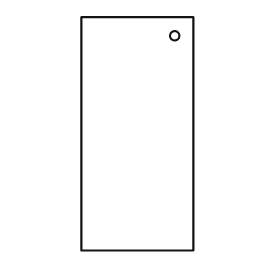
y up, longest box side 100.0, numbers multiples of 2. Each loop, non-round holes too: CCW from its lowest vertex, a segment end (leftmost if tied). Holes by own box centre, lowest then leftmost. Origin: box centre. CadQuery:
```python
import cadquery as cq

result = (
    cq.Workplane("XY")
    .moveTo(-24.0, -50.0)
    .lineTo(24.0, -50.0)
    .lineTo(24.0, 50.0)
    .lineTo(-24.0, 50.0)
    .close()
    .moveTo(16.0, 42.0)
    .circle(2.0)
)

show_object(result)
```